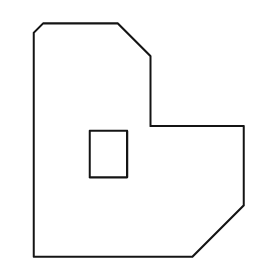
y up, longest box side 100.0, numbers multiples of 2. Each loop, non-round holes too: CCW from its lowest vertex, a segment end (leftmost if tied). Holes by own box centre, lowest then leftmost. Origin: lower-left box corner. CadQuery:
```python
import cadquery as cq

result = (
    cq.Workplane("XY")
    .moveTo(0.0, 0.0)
    .lineTo(68.0, 0.0)
    .lineTo(90.0, 22.0)
    .lineTo(90.0, 56.0)
    .lineTo(50.0, 56.0)
    .lineTo(50.0, 86.0)
    .lineTo(36.0, 100.0)
    .lineTo(4.0, 100.0)
    .lineTo(0.0, 96.0)
    .close()
    .moveTo(24.0, 34.0)
    .lineTo(40.0, 34.0)
    .lineTo(40.0, 54.0)
    .lineTo(24.0, 54.0)
    .close()
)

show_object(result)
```